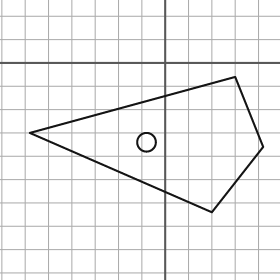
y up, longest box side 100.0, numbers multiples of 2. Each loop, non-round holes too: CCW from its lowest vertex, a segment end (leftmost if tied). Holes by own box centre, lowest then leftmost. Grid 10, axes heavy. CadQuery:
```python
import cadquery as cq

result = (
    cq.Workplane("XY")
    .moveTo(20.0, -64.0)
    .lineTo(42.0, -36.0)
    .lineTo(30.0, -6.0)
    .lineTo(-58.0, -30.0)
    .close()
    .moveTo(-8.0, -34.0)
    .circle(4.0)
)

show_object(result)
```